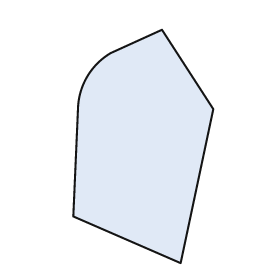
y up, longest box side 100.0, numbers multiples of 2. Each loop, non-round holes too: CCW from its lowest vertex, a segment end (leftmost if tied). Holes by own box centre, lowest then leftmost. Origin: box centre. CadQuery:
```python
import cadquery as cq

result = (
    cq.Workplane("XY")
    .moveTo(16.0, -50.0)
    .lineTo(30.0, 16.0)
    .lineTo(8.0, 50.0)
    .lineTo(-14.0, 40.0)
    .threePointArc((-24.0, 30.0), (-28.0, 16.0))
    .lineTo(-30.0, -30.0)
    .close()
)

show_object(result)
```